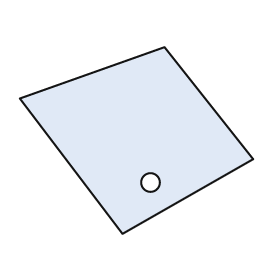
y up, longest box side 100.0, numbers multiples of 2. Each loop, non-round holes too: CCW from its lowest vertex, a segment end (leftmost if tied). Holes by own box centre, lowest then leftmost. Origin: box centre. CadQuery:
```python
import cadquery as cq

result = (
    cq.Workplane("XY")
    .moveTo(-6.0, -40.0)
    .lineTo(50.0, -8.0)
    .lineTo(12.0, 40.0)
    .lineTo(-50.0, 18.0)
    .close()
    .moveTo(6.0, -18.0)
    .circle(4.0)
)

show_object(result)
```